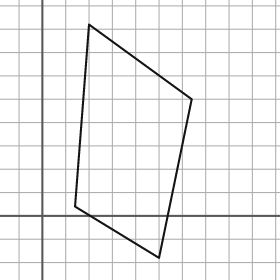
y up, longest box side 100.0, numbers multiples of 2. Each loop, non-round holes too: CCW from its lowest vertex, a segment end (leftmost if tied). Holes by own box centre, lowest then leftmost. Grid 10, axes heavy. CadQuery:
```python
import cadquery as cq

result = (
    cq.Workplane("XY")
    .moveTo(50.0, -18.0)
    .lineTo(64.0, 50.0)
    .lineTo(20.0, 82.0)
    .lineTo(14.0, 4.0)
    .close()
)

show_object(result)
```